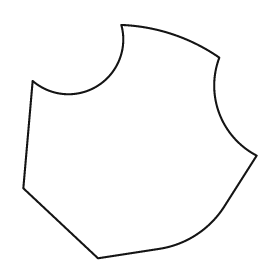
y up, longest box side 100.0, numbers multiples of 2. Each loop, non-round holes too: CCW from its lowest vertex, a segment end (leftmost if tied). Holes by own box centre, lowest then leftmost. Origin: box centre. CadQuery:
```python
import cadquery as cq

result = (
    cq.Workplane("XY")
    .moveTo(-18.0, -50.0)
    .lineTo(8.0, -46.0)
    .threePointArc((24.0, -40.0), (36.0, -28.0))
    .lineTo(50.0, -6.0)
    .threePointArc((34.0, 12.0), (34.0, 36.0))
    .threePointArc((14.0, 46.0), (-8.0, 50.0))
    .threePointArc((-18.0, 24.0), (-46.0, 26.0))
    .lineTo(-50.0, -20.0)
    .close()
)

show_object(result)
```